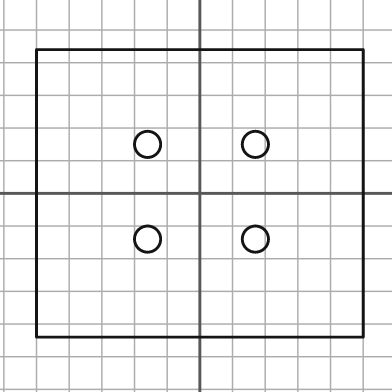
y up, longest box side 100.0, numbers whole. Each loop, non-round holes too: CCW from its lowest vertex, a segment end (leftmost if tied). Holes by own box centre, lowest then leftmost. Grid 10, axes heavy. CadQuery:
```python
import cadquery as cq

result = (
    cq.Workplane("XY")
    .moveTo(-50.0, -44.0)
    .lineTo(50.0, -44.0)
    .lineTo(50.0, 44.0)
    .lineTo(-50.0, 44.0)
    .close()
    .moveTo(-16.0, -14.0)
    .circle(4.0)
    .moveTo(17.0, -14.0)
    .circle(4.0)
    .moveTo(-16.0, 15.0)
    .circle(4.0)
    .moveTo(17.0, 15.0)
    .circle(4.0)
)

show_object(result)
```